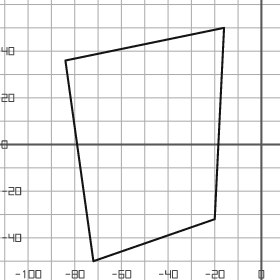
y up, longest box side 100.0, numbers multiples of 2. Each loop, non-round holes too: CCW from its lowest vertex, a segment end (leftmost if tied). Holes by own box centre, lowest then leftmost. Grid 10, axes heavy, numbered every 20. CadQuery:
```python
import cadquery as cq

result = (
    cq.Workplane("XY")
    .moveTo(-72.0, -50.0)
    .lineTo(-20.0, -32.0)
    .lineTo(-16.0, 50.0)
    .lineTo(-84.0, 36.0)
    .close()
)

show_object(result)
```